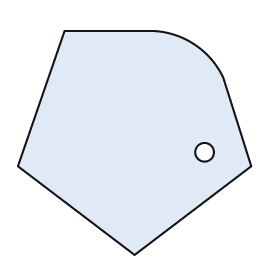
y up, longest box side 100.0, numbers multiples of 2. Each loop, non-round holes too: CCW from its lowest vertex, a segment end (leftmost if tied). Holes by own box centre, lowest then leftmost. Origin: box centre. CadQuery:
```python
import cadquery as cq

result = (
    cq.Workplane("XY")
    .moveTo(0.0, -48.0)
    .lineTo(50.0, -10.0)
    .lineTo(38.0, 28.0)
    .threePointArc((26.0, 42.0), (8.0, 48.0))
    .lineTo(-30.0, 48.0)
    .lineTo(-50.0, -10.0)
    .close()
    .moveTo(30.0, -4.0)
    .circle(4.0)
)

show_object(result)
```